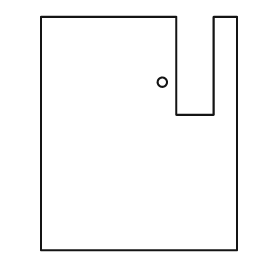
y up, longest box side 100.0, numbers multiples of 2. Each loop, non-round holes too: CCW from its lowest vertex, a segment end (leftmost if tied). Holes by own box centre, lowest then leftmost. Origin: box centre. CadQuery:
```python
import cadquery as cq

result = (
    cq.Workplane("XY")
    .moveTo(-42.0, -50.0)
    .lineTo(42.0, -50.0)
    .lineTo(42.0, 50.0)
    .lineTo(32.0, 50.0)
    .lineTo(32.0, 8.0)
    .lineTo(16.0, 8.0)
    .lineTo(16.0, 50.0)
    .lineTo(-42.0, 50.0)
    .close()
    .moveTo(10.0, 22.0)
    .circle(2.0)
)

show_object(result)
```